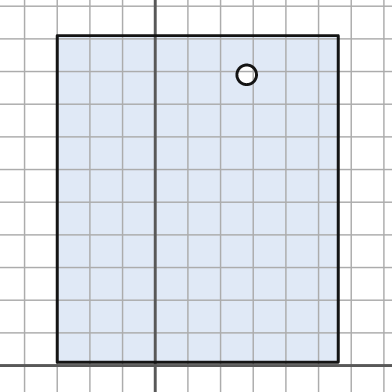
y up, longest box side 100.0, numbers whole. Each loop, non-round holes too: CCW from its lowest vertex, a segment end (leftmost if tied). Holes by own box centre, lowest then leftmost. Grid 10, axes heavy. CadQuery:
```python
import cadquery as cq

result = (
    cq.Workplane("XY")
    .moveTo(-30.0, 1.0)
    .lineTo(56.0, 1.0)
    .lineTo(56.0, 101.0)
    .lineTo(-30.0, 101.0)
    .close()
    .moveTo(28.0, 89.0)
    .circle(3.0)
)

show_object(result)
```